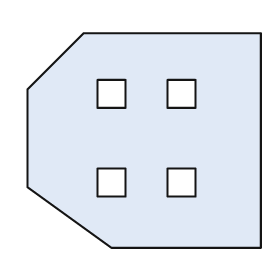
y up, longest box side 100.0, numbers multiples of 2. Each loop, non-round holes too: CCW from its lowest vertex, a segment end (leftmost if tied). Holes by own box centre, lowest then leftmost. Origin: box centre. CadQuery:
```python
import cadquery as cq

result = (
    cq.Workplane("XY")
    .moveTo(-14.0, -46.0)
    .lineTo(50.0, -46.0)
    .lineTo(50.0, 46.0)
    .lineTo(-26.0, 46.0)
    .lineTo(-50.0, 22.0)
    .lineTo(-50.0, -20.0)
    .close()
    .moveTo(-20.0, -24.0)
    .lineTo(-8.0, -24.0)
    .lineTo(-8.0, -12.0)
    .lineTo(-20.0, -12.0)
    .close()
    .moveTo(10.0, -24.0)
    .lineTo(22.0, -24.0)
    .lineTo(22.0, -12.0)
    .lineTo(10.0, -12.0)
    .close()
    .moveTo(-20.0, 14.0)
    .lineTo(-8.0, 14.0)
    .lineTo(-8.0, 26.0)
    .lineTo(-20.0, 26.0)
    .close()
    .moveTo(10.0, 14.0)
    .lineTo(22.0, 14.0)
    .lineTo(22.0, 26.0)
    .lineTo(10.0, 26.0)
    .close()
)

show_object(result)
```